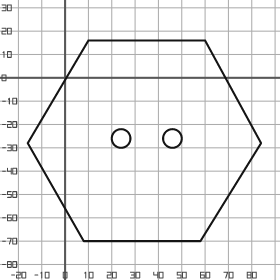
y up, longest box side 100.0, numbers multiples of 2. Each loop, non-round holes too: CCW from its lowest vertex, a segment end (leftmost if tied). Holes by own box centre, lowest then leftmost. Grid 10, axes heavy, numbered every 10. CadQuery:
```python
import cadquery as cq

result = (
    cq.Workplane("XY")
    .moveTo(8.0, -70.0)
    .lineTo(58.0, -70.0)
    .lineTo(84.0, -28.0)
    .lineTo(60.0, 16.0)
    .lineTo(10.0, 16.0)
    .lineTo(-16.0, -28.0)
    .close()
    .moveTo(24.0, -26.0)
    .circle(4.0)
    .moveTo(46.0, -26.0)
    .circle(4.0)
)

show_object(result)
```